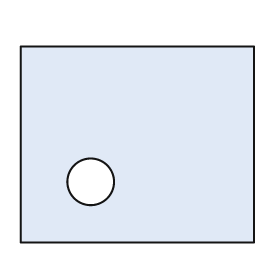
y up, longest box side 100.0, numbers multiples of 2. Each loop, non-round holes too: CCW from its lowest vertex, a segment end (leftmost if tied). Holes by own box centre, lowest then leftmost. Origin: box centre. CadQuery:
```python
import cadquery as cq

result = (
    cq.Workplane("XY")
    .moveTo(-50.0, -42.0)
    .lineTo(50.0, -42.0)
    .lineTo(50.0, 42.0)
    .lineTo(-50.0, 42.0)
    .close()
    .moveTo(-20.0, -16.0)
    .circle(10.0)
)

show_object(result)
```